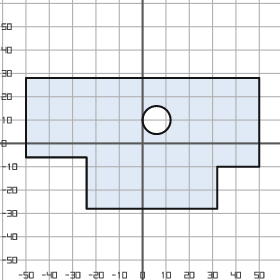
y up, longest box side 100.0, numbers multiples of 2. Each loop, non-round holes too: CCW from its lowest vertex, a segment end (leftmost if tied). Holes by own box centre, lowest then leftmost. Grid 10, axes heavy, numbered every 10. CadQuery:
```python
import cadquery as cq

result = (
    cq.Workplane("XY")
    .moveTo(-24.0, -28.0)
    .lineTo(32.0, -28.0)
    .lineTo(32.0, -10.0)
    .lineTo(50.0, -10.0)
    .lineTo(50.0, 28.0)
    .lineTo(-50.0, 28.0)
    .lineTo(-50.0, -6.0)
    .lineTo(-24.0, -6.0)
    .close()
    .moveTo(6.0, 10.0)
    .circle(6.0)
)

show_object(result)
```